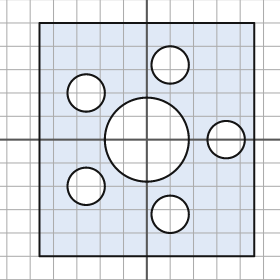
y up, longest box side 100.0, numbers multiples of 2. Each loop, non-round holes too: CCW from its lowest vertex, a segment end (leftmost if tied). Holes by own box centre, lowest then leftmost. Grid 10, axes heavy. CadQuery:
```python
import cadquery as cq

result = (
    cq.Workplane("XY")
    .moveTo(-46.0, -50.0)
    .lineTo(46.0, -50.0)
    .lineTo(46.0, 50.0)
    .lineTo(-46.0, 50.0)
    .close()
    .moveTo(10.0, -32.0)
    .circle(8.0)
    .moveTo(-26.0, -20.0)
    .circle(8.0)
    .moveTo(0.0, 0.0)
    .circle(18.0)
    .moveTo(34.0, 0.0)
    .circle(8.0)
    .moveTo(-26.0, 20.0)
    .circle(8.0)
    .moveTo(10.0, 32.0)
    .circle(8.0)
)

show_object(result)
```